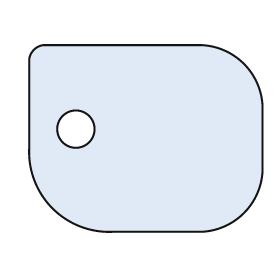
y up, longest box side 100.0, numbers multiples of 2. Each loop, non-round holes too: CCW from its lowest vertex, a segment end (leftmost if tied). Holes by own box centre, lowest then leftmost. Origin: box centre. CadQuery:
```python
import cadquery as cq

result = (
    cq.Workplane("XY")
    .moveTo(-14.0, -40.0)
    .lineTo(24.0, -40.0)
    .threePointArc((42.0, -32.0), (50.0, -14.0))
    .lineTo(50.0, 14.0)
    .threePointArc((42.0, 32.0), (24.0, 40.0))
    .lineTo(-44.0, 40.0)
    .threePointArc((-48.0, 38.0), (-50.0, 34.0))
    .lineTo(-50.0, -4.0)
    .threePointArc((-40.0, -30.0), (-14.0, -40.0))
    .close()
    .moveTo(-30.0, 4.0)
    .circle(8.0)
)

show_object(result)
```